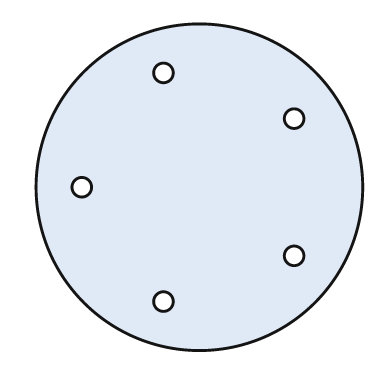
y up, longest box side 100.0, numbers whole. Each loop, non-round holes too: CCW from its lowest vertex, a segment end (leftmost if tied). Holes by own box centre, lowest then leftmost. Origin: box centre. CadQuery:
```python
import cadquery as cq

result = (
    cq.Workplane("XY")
    .moveTo(0.0, 0.0)
    .circle(50.0)
    .moveTo(-11.0, -35.0)
    .circle(3.0)
    .moveTo(29.0, -21.0)
    .circle(3.0)
    .moveTo(-36.0, 0.0)
    .circle(3.0)
    .moveTo(29.0, 21.0)
    .circle(3.0)
    .moveTo(-11.0, 35.0)
    .circle(3.0)
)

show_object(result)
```